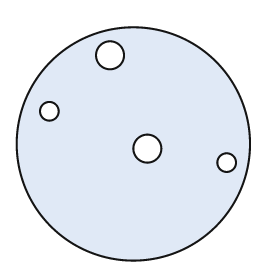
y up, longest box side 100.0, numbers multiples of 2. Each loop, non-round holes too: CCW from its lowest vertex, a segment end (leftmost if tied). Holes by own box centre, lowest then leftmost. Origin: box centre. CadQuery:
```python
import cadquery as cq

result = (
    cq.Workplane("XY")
    .moveTo(0.0, 0.0)
    .circle(50.0)
    .moveTo(40.0, -8.0)
    .circle(4.0)
    .moveTo(6.0, -2.0)
    .circle(6.0)
    .moveTo(-36.0, 14.0)
    .circle(4.0)
    .moveTo(-10.0, 38.0)
    .circle(6.0)
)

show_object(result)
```